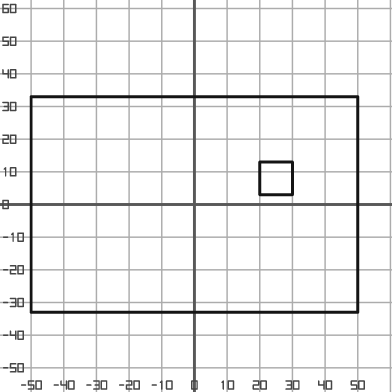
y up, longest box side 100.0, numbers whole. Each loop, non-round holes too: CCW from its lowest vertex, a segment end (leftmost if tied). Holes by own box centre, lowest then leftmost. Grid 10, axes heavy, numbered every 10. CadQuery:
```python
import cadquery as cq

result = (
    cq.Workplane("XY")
    .moveTo(-50.0, -33.0)
    .lineTo(50.0, -33.0)
    .lineTo(50.0, 33.0)
    .lineTo(-50.0, 33.0)
    .close()
    .moveTo(20.0, 3.0)
    .lineTo(30.0, 3.0)
    .lineTo(30.0, 13.0)
    .lineTo(20.0, 13.0)
    .close()
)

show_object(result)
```